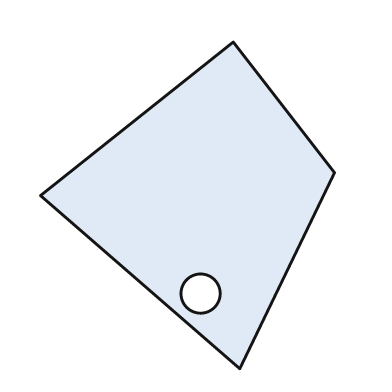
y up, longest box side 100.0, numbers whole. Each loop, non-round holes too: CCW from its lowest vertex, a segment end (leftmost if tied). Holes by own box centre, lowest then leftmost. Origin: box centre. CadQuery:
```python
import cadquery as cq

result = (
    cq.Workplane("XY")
    .moveTo(16.0, -50.0)
    .lineTo(45.0, 10.0)
    .lineTo(14.0, 50.0)
    .lineTo(-45.0, 3.0)
    .close()
    .moveTo(4.0, -27.0)
    .circle(6.0)
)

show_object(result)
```